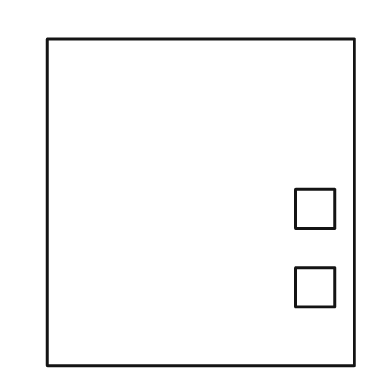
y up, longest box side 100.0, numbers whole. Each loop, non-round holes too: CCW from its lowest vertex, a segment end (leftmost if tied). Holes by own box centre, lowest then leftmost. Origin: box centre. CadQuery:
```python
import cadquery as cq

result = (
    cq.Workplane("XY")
    .moveTo(-47.0, -50.0)
    .lineTo(47.0, -50.0)
    .lineTo(47.0, 50.0)
    .lineTo(-47.0, 50.0)
    .close()
    .moveTo(29.0, -32.0)
    .lineTo(41.0, -32.0)
    .lineTo(41.0, -20.0)
    .lineTo(29.0, -20.0)
    .close()
    .moveTo(29.0, -8.0)
    .lineTo(41.0, -8.0)
    .lineTo(41.0, 4.0)
    .lineTo(29.0, 4.0)
    .close()
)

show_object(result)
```